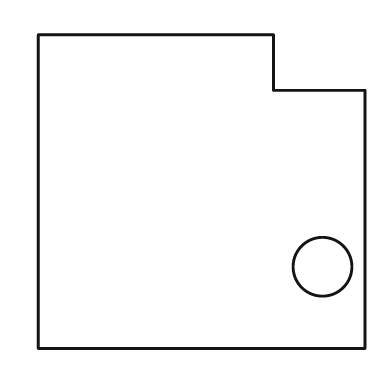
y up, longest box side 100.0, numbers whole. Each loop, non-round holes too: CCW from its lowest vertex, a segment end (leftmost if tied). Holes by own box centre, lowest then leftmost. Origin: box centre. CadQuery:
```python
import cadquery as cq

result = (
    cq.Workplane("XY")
    .moveTo(-50.0, -48.0)
    .lineTo(50.0, -48.0)
    .lineTo(50.0, 31.0)
    .lineTo(22.0, 31.0)
    .lineTo(22.0, 48.0)
    .lineTo(-50.0, 48.0)
    .close()
    .moveTo(37.0, -23.0)
    .circle(9.0)
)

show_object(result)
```